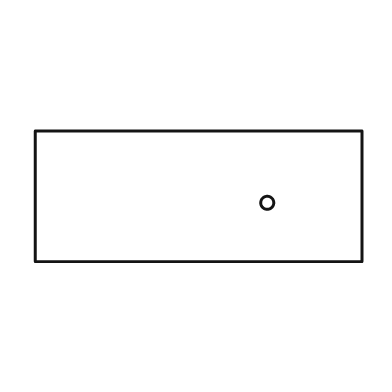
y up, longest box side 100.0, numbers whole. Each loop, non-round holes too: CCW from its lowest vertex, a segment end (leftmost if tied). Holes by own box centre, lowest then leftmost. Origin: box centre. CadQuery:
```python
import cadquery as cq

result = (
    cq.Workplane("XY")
    .moveTo(-50.0, -20.0)
    .lineTo(50.0, -20.0)
    .lineTo(50.0, 20.0)
    .lineTo(-50.0, 20.0)
    .close()
    .moveTo(21.0, -2.0)
    .circle(2.0)
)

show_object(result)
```